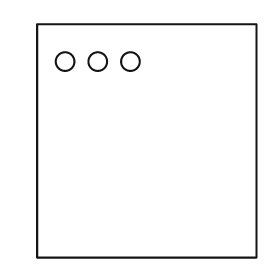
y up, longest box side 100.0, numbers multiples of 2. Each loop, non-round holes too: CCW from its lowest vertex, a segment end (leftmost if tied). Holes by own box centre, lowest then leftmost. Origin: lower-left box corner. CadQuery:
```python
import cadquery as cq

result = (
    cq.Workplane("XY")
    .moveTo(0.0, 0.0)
    .lineTo(94.0, 0.0)
    .lineTo(94.0, 100.0)
    .lineTo(0.0, 100.0)
    .close()
    .moveTo(12.0, 84.0)
    .circle(4.0)
    .moveTo(26.0, 84.0)
    .circle(4.0)
    .moveTo(40.0, 84.0)
    .circle(4.0)
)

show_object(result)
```